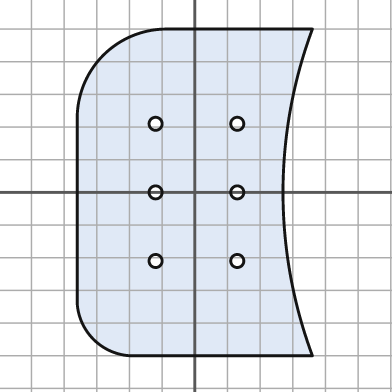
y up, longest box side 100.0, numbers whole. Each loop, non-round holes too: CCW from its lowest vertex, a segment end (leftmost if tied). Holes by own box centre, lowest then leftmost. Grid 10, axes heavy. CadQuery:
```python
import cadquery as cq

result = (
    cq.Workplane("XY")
    .moveTo(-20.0, -50.0)
    .lineTo(36.0, -50.0)
    .threePointArc((27.0, 0.0), (36.0, 50.0))
    .lineTo(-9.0, 50.0)
    .threePointArc((-28.0, 42.0), (-36.0, 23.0))
    .lineTo(-36.0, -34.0)
    .threePointArc((-31.0, -45.0), (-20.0, -50.0))
    .close()
    .moveTo(-12.0, -21.0)
    .circle(2.0)
    .moveTo(13.0, -21.0)
    .circle(2.0)
    .moveTo(-12.0, 0.0)
    .circle(2.0)
    .moveTo(13.0, 0.0)
    .circle(2.0)
    .moveTo(-12.0, 21.0)
    .circle(2.0)
    .moveTo(13.0, 21.0)
    .circle(2.0)
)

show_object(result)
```